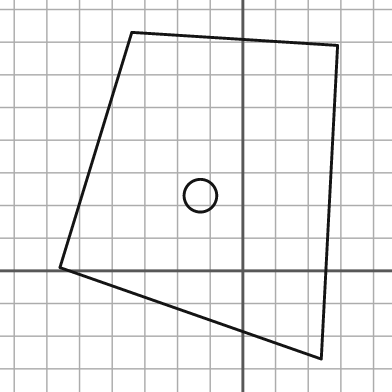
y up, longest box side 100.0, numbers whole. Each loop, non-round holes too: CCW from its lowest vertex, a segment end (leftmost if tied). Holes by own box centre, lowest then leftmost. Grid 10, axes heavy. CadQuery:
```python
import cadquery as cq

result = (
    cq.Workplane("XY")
    .moveTo(24.0, -27.0)
    .lineTo(29.0, 69.0)
    .lineTo(-34.0, 73.0)
    .lineTo(-56.0, 1.0)
    .close()
    .moveTo(-13.0, 23.0)
    .circle(5.0)
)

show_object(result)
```